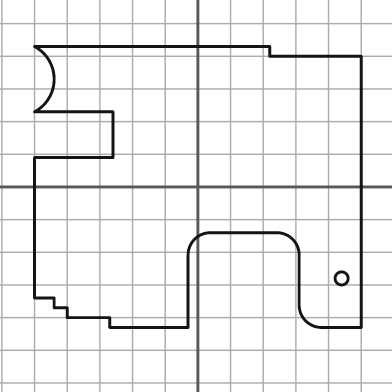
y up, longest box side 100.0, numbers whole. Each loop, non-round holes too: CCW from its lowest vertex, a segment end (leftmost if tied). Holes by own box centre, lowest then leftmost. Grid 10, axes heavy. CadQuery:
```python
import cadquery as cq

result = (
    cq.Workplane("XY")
    .moveTo(-27.0, -43.0)
    .lineTo(-3.0, -43.0)
    .lineTo(-3.0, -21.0)
    .threePointArc((-1.0, -16.0), (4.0, -14.0))
    .lineTo(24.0, -14.0)
    .threePointArc((29.0, -16.0), (31.0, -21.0))
    .lineTo(31.0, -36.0)
    .threePointArc((33.0, -41.0), (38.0, -43.0))
    .lineTo(50.0, -43.0)
    .lineTo(50.0, 40.0)
    .lineTo(22.0, 40.0)
    .lineTo(22.0, 43.0)
    .lineTo(-50.0, 43.0)
    .threePointArc((-44.0, 33.0), (-50.0, 23.0))
    .lineTo(-26.0, 23.0)
    .lineTo(-26.0, 9.0)
    .lineTo(-50.0, 9.0)
    .lineTo(-50.0, -34.0)
    .lineTo(-44.0, -34.0)
    .lineTo(-44.0, -37.0)
    .lineTo(-40.0, -37.0)
    .lineTo(-40.0, -40.0)
    .lineTo(-27.0, -40.0)
    .close()
    .moveTo(44.0, -28.0)
    .circle(2.0)
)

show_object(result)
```